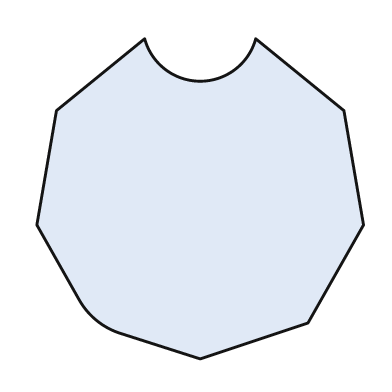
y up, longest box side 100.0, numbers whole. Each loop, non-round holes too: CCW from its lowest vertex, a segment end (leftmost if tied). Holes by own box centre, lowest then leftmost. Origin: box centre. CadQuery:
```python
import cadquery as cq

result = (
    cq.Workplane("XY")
    .moveTo(0.0, -49.0)
    .lineTo(33.0, -38.0)
    .lineTo(50.0, -8.0)
    .lineTo(44.0, 27.0)
    .lineTo(17.0, 49.0)
    .threePointArc((0.0, 36.0), (-17.0, 49.0))
    .lineTo(-44.0, 27.0)
    .lineTo(-50.0, -8.0)
    .lineTo(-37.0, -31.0)
    .threePointArc((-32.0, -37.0), (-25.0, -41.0))
    .close()
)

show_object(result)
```